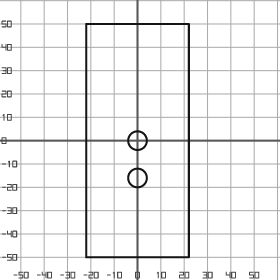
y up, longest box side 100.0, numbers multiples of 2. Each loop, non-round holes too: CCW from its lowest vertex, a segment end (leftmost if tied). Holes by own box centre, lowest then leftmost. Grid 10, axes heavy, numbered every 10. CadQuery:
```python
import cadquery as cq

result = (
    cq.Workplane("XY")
    .moveTo(-22.0, -50.0)
    .lineTo(22.0, -50.0)
    .lineTo(22.0, 50.0)
    .lineTo(-22.0, 50.0)
    .close()
    .moveTo(0.0, -16.0)
    .circle(4.0)
    .moveTo(0.0, 0.0)
    .circle(4.0)
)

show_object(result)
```